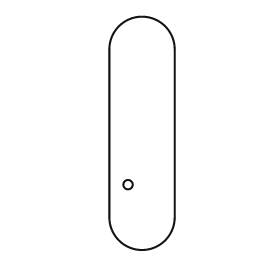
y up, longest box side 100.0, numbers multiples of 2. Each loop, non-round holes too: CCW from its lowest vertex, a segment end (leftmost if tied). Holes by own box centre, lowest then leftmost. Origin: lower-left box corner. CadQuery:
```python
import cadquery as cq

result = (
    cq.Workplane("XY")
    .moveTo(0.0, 14.0)
    .threePointArc((14.0, 0.0), (28.0, 14.0))
    .lineTo(28.0, 86.0)
    .threePointArc((14.0, 100.0), (0.0, 86.0))
    .close()
    .moveTo(8.0, 28.0)
    .circle(2.0)
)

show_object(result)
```